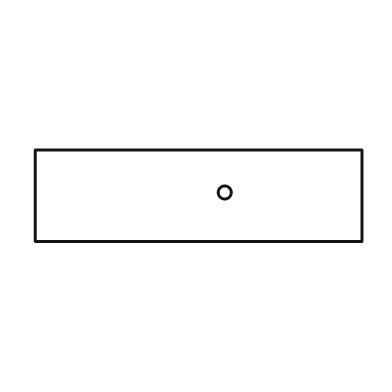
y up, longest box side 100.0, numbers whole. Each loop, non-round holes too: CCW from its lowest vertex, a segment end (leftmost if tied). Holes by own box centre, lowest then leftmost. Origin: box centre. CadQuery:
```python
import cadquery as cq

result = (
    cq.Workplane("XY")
    .moveTo(-50.0, -14.0)
    .lineTo(50.0, -14.0)
    .lineTo(50.0, 14.0)
    .lineTo(-50.0, 14.0)
    .close()
    .moveTo(8.0, 1.0)
    .circle(2.0)
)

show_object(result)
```